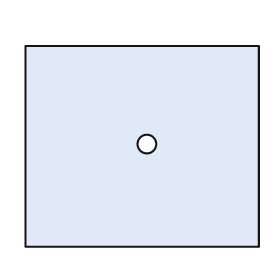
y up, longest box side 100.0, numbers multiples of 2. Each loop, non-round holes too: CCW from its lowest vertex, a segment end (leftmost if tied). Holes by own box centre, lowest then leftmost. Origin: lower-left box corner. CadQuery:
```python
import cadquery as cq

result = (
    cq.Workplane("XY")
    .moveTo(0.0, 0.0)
    .lineTo(100.0, 0.0)
    .lineTo(100.0, 86.0)
    .lineTo(0.0, 86.0)
    .close()
    .moveTo(52.0, 44.0)
    .circle(4.0)
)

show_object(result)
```